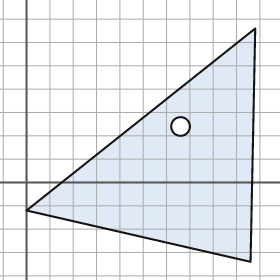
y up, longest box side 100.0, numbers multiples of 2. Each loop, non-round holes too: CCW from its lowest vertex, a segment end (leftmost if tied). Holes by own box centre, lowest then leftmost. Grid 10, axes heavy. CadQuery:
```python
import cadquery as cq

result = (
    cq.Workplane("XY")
    .moveTo(96.0, -34.0)
    .lineTo(98.0, 66.0)
    .lineTo(0.0, -12.0)
    .close()
    .moveTo(66.0, 24.0)
    .circle(4.0)
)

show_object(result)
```